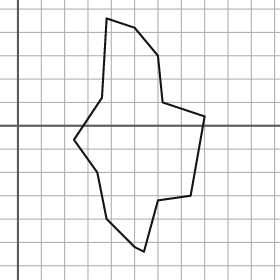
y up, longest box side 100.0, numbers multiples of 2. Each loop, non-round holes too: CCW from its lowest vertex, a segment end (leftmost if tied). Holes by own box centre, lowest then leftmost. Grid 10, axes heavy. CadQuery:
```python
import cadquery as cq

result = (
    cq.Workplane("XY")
    .moveTo(54.0, -54.0)
    .lineTo(60.0, -32.0)
    .lineTo(74.0, -30.0)
    .lineTo(80.0, 4.0)
    .lineTo(62.0, 10.0)
    .lineTo(60.0, 30.0)
    .lineTo(50.0, 42.0)
    .lineTo(38.0, 46.0)
    .lineTo(36.0, 12.0)
    .lineTo(24.0, -6.0)
    .lineTo(34.0, -20.0)
    .lineTo(38.0, -40.0)
    .lineTo(50.0, -52.0)
    .close()
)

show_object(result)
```